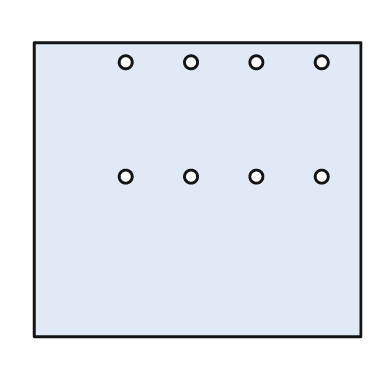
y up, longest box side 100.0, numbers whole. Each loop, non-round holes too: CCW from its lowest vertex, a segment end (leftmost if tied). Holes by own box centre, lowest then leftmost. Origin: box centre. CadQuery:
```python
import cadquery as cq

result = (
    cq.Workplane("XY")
    .moveTo(-50.0, -45.0)
    .lineTo(50.0, -45.0)
    .lineTo(50.0, 45.0)
    .lineTo(-50.0, 45.0)
    .close()
    .moveTo(-22.0, 4.0)
    .circle(2.0)
    .moveTo(-2.0, 4.0)
    .circle(2.0)
    .moveTo(18.0, 4.0)
    .circle(2.0)
    .moveTo(38.0, 4.0)
    .circle(2.0)
    .moveTo(-22.0, 39.0)
    .circle(2.0)
    .moveTo(-2.0, 39.0)
    .circle(2.0)
    .moveTo(18.0, 39.0)
    .circle(2.0)
    .moveTo(38.0, 39.0)
    .circle(2.0)
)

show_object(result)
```